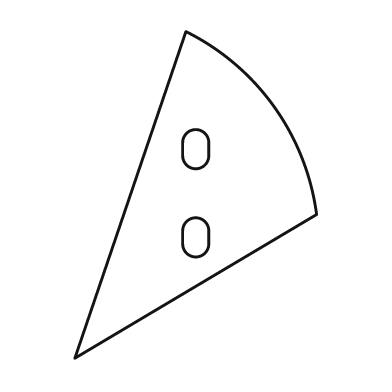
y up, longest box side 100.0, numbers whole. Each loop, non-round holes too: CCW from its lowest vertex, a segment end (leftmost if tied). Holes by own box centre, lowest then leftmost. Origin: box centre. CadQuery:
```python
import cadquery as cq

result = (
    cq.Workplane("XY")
    .moveTo(-37.0, -50.0)
    .lineTo(37.0, -6.0)
    .threePointArc((24.0, 27.0), (-3.0, 50.0))
    .close()
    .moveTo(-4.0, -15.0)
    .threePointArc((0.0, -19.0), (4.0, -15.0))
    .lineTo(4.0, -11.0)
    .threePointArc((0.0, -7.0), (-4.0, -11.0))
    .close()
    .moveTo(-4.0, 12.0)
    .threePointArc((0.0, 8.0), (4.0, 12.0))
    .lineTo(4.0, 16.0)
    .threePointArc((0.0, 20.0), (-4.0, 16.0))
    .close()
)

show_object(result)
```